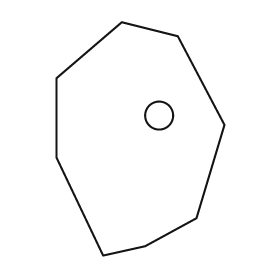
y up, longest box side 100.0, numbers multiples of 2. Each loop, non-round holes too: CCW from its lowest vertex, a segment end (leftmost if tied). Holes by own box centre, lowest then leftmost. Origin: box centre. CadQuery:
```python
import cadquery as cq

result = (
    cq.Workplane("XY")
    .moveTo(-16.0, -50.0)
    .lineTo(2.0, -46.0)
    .lineTo(24.0, -34.0)
    .lineTo(36.0, 6.0)
    .lineTo(16.0, 44.0)
    .lineTo(-8.0, 50.0)
    .lineTo(-36.0, 26.0)
    .lineTo(-36.0, -8.0)
    .close()
    .moveTo(8.0, 10.0)
    .circle(6.0)
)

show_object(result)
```